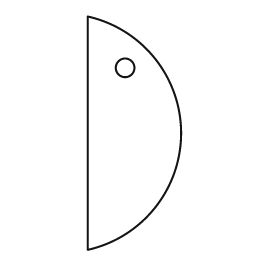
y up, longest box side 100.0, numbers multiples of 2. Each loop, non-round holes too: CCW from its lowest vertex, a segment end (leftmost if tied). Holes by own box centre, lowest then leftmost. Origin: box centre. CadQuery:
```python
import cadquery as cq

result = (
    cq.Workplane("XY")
    .moveTo(-20.0, -50.0)
    .threePointArc((20.0, 0.0), (-20.0, 50.0))
    .close()
    .moveTo(-4.0, 28.0)
    .circle(4.0)
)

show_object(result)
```